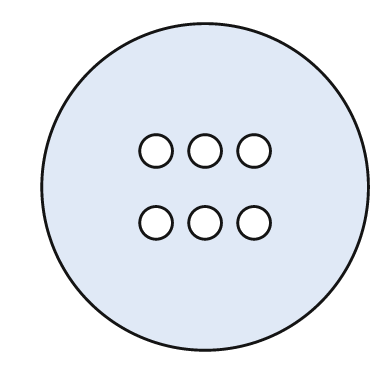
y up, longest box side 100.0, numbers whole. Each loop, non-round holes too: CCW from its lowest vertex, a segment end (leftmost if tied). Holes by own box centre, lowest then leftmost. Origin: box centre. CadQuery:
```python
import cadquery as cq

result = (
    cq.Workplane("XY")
    .moveTo(0.0, 0.0)
    .circle(50.0)
    .moveTo(-15.0, -11.0)
    .circle(5.0)
    .moveTo(0.0, -11.0)
    .circle(5.0)
    .moveTo(15.0, -11.0)
    .circle(5.0)
    .moveTo(-15.0, 11.0)
    .circle(5.0)
    .moveTo(0.0, 11.0)
    .circle(5.0)
    .moveTo(15.0, 11.0)
    .circle(5.0)
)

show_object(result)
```